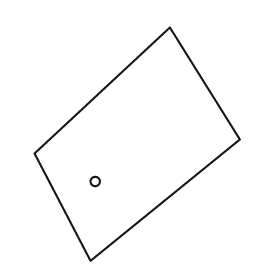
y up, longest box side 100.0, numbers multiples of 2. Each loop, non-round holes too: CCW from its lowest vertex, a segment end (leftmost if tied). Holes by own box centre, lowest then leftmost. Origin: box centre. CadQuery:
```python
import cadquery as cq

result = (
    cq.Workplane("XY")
    .moveTo(-20.0, -50.0)
    .lineTo(44.0, 2.0)
    .lineTo(14.0, 50.0)
    .lineTo(-44.0, -4.0)
    .close()
    .moveTo(-18.0, -16.0)
    .circle(2.0)
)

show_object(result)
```